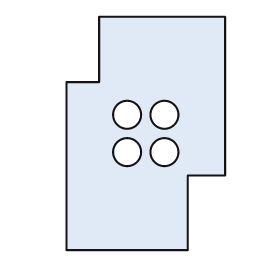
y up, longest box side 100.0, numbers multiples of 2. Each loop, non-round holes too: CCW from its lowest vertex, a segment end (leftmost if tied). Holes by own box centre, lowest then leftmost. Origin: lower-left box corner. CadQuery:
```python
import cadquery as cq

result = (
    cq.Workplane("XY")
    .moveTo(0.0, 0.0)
    .lineTo(52.0, 0.0)
    .lineTo(52.0, 32.0)
    .lineTo(68.0, 32.0)
    .lineTo(68.0, 100.0)
    .lineTo(14.0, 100.0)
    .lineTo(14.0, 72.0)
    .lineTo(0.0, 72.0)
    .close()
    .moveTo(26.0, 42.0)
    .circle(6.0)
    .moveTo(42.0, 42.0)
    .circle(6.0)
    .moveTo(26.0, 58.0)
    .circle(6.0)
    .moveTo(42.0, 58.0)
    .circle(6.0)
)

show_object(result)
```